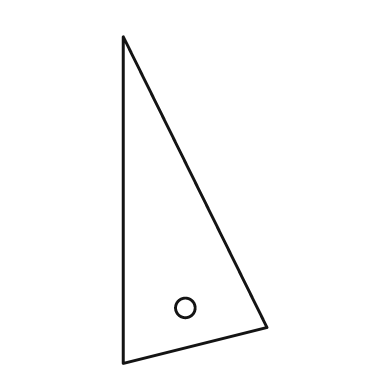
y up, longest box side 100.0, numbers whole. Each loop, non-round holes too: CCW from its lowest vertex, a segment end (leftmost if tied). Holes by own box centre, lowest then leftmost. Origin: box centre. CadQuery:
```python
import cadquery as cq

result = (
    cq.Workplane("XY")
    .moveTo(-22.0, -50.0)
    .lineTo(22.0, -39.0)
    .lineTo(-22.0, 50.0)
    .close()
    .moveTo(-3.0, -33.0)
    .circle(3.0)
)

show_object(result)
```